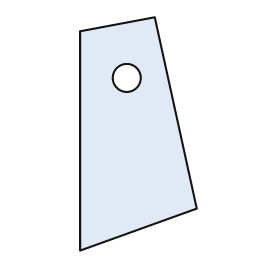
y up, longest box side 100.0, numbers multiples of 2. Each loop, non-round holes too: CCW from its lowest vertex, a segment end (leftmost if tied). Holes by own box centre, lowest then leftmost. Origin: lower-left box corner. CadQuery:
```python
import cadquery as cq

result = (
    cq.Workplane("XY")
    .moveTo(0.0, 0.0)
    .lineTo(50.0, 18.0)
    .lineTo(32.0, 100.0)
    .lineTo(0.0, 94.0)
    .close()
    .moveTo(20.0, 74.0)
    .circle(6.0)
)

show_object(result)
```